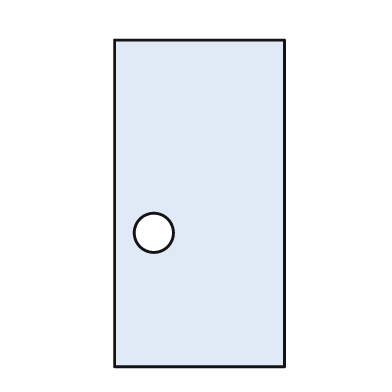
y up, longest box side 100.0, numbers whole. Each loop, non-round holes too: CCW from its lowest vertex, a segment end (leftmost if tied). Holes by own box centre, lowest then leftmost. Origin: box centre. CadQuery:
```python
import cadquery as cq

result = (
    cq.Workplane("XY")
    .moveTo(-26.0, -50.0)
    .lineTo(26.0, -50.0)
    .lineTo(26.0, 50.0)
    .lineTo(-26.0, 50.0)
    .close()
    .moveTo(-14.0, -9.0)
    .circle(6.0)
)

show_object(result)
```